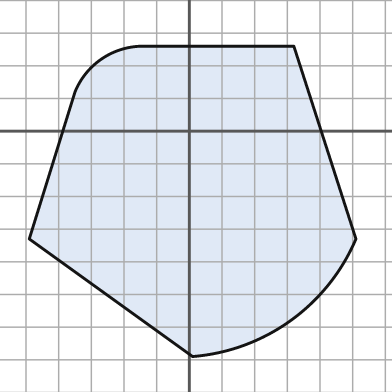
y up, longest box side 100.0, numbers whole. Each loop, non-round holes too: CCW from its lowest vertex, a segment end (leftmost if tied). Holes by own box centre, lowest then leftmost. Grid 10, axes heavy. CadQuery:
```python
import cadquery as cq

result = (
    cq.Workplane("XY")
    .moveTo(1.0, -69.0)
    .threePointArc((31.0, -58.0), (51.0, -33.0))
    .lineTo(32.0, 26.0)
    .lineTo(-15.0, 26.0)
    .threePointArc((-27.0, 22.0), (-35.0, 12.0))
    .lineTo(-49.0, -33.0)
    .close()
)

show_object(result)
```